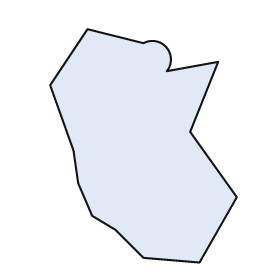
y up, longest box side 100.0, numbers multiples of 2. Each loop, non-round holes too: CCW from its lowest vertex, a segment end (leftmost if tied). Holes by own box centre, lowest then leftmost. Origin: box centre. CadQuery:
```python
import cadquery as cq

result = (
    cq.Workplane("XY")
    .moveTo(24.0, -50.0)
    .lineTo(40.0, -22.0)
    .lineTo(20.0, 6.0)
    .lineTo(32.0, 36.0)
    .lineTo(10.0, 32.0)
    .threePointArc((10.0, 42.0), (0.0, 44.0))
    .lineTo(-24.0, 50.0)
    .lineTo(-40.0, 26.0)
    .lineTo(-30.0, -2.0)
    .lineTo(-28.0, -16.0)
    .lineTo(-22.0, -30.0)
    .lineTo(-12.0, -36.0)
    .lineTo(0.0, -48.0)
    .close()
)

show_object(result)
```